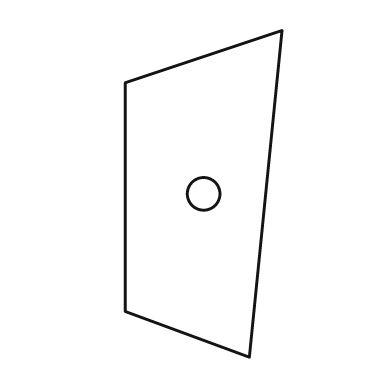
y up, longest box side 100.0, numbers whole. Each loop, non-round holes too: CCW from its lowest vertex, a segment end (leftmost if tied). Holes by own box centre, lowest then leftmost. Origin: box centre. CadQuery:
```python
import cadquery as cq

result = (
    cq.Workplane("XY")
    .moveTo(14.0, -50.0)
    .lineTo(24.0, 50.0)
    .lineTo(-24.0, 34.0)
    .lineTo(-24.0, -36.0)
    .close()
    .moveTo(0.0, 0.0)
    .circle(5.0)
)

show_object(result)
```